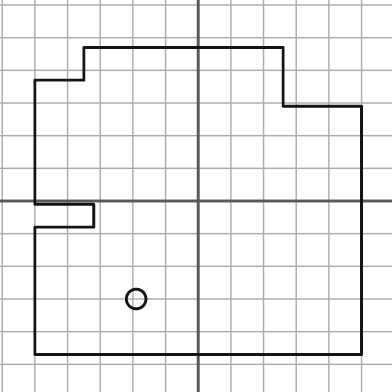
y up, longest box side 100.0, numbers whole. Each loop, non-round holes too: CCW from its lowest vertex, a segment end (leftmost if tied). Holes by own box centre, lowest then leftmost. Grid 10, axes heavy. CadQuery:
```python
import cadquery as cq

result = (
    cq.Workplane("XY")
    .moveTo(-50.0, -47.0)
    .lineTo(50.0, -47.0)
    .lineTo(50.0, 29.0)
    .lineTo(26.0, 29.0)
    .lineTo(26.0, 47.0)
    .lineTo(-35.0, 47.0)
    .lineTo(-35.0, 37.0)
    .lineTo(-50.0, 37.0)
    .lineTo(-50.0, -1.0)
    .lineTo(-32.0, -1.0)
    .lineTo(-32.0, -8.0)
    .lineTo(-50.0, -8.0)
    .close()
    .moveTo(-19.0, -30.0)
    .circle(3.0)
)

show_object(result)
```